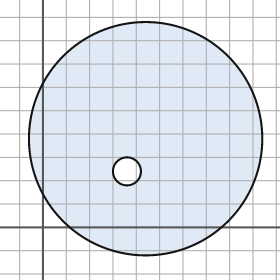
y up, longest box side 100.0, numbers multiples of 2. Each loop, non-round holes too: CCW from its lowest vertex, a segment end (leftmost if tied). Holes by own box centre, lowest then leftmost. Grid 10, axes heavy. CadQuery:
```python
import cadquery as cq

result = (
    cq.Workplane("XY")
    .moveTo(44.0, 38.0)
    .circle(50.0)
    .moveTo(36.0, 24.0)
    .circle(6.0)
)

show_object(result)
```